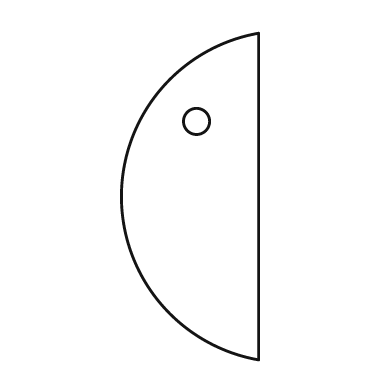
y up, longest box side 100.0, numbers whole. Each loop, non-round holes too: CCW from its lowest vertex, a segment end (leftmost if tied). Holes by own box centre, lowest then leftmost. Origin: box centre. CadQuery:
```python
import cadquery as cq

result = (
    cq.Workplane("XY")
    .moveTo(21.0, -50.0)
    .lineTo(21.0, 50.0)
    .threePointArc((-21.0, 0.0), (21.0, -50.0))
    .close()
    .moveTo(2.0, 23.0)
    .circle(4.0)
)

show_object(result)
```